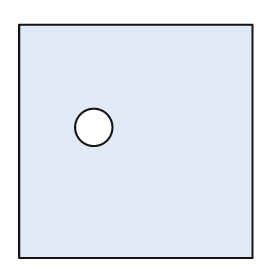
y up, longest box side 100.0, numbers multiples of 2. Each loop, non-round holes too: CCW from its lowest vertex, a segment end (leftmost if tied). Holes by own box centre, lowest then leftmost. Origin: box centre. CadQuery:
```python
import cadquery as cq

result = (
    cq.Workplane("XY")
    .moveTo(-50.0, -50.0)
    .lineTo(50.0, -50.0)
    .lineTo(50.0, 50.0)
    .lineTo(-50.0, 50.0)
    .close()
    .moveTo(-18.0, 6.0)
    .circle(8.0)
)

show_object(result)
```